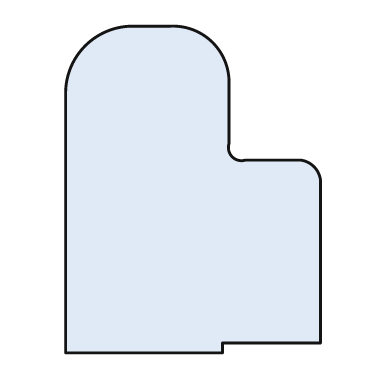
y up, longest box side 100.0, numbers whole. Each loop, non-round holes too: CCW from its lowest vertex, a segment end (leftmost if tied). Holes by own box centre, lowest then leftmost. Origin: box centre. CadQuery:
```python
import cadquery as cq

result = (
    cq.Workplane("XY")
    .moveTo(-39.0, -50.0)
    .lineTo(9.0, -50.0)
    .lineTo(9.0, -47.0)
    .lineTo(39.0, -47.0)
    .lineTo(39.0, 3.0)
    .threePointArc((37.0, 7.0), (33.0, 9.0))
    .lineTo(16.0, 9.0)
    .threePointArc((12.0, 10.0), (11.0, 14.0))
    .lineTo(11.0, 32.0)
    .threePointArc((6.0, 45.0), (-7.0, 50.0))
    .lineTo(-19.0, 50.0)
    .threePointArc((-33.0, 44.0), (-39.0, 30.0))
    .close()
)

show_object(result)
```